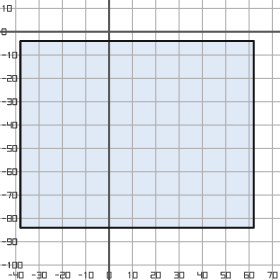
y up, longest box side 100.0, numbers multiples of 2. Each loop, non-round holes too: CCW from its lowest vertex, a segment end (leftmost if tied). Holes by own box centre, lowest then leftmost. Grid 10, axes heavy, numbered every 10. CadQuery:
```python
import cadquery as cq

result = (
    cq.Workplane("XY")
    .moveTo(-38.0, -84.0)
    .lineTo(62.0, -84.0)
    .lineTo(62.0, -4.0)
    .lineTo(-38.0, -4.0)
    .close()
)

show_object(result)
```